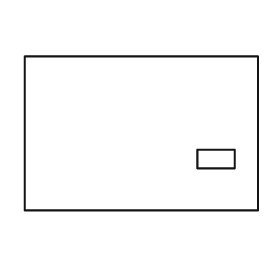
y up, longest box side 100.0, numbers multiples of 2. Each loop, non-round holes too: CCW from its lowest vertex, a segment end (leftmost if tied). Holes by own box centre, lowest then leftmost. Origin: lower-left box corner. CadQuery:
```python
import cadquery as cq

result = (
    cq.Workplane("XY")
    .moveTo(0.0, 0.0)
    .lineTo(100.0, 0.0)
    .lineTo(100.0, 66.0)
    .lineTo(0.0, 66.0)
    .close()
    .moveTo(74.0, 18.0)
    .lineTo(90.0, 18.0)
    .lineTo(90.0, 26.0)
    .lineTo(74.0, 26.0)
    .close()
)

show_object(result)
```